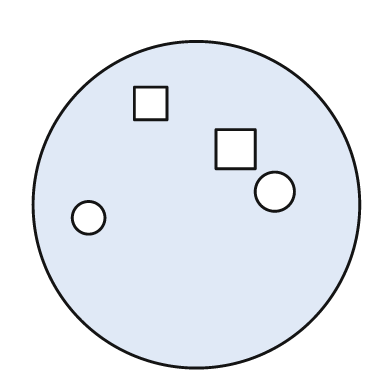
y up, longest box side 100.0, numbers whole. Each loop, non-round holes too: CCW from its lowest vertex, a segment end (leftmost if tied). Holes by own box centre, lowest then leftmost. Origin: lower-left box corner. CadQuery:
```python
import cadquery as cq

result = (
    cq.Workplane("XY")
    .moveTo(50.0, 50.0)
    .circle(50.0)
    .moveTo(17.0, 46.0)
    .circle(5.0)
    .moveTo(74.0, 54.0)
    .circle(6.0)
    .moveTo(56.0, 61.0)
    .lineTo(68.0, 61.0)
    .lineTo(68.0, 73.0)
    .lineTo(56.0, 73.0)
    .close()
    .moveTo(31.0, 76.0)
    .lineTo(41.0, 76.0)
    .lineTo(41.0, 86.0)
    .lineTo(31.0, 86.0)
    .close()
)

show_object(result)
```